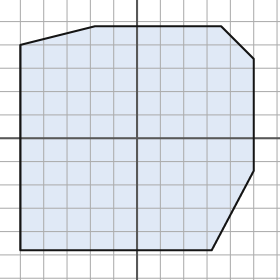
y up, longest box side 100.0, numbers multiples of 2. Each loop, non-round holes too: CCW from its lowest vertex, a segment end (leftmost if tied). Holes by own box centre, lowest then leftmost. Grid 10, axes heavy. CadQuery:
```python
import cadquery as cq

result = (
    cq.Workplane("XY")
    .moveTo(-50.0, -48.0)
    .lineTo(32.0, -48.0)
    .lineTo(50.0, -14.0)
    .lineTo(50.0, 34.0)
    .lineTo(36.0, 48.0)
    .lineTo(-18.0, 48.0)
    .lineTo(-50.0, 40.0)
    .close()
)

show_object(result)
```